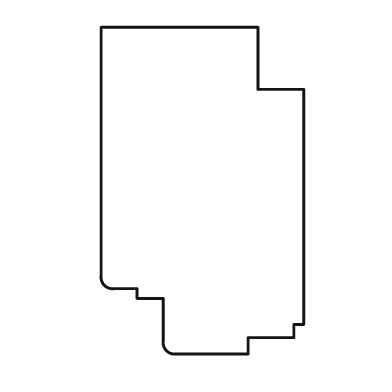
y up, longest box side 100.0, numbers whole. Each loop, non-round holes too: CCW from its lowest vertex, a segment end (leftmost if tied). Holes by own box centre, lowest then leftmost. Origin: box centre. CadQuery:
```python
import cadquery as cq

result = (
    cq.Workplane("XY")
    .moveTo(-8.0, -50.0)
    .lineTo(14.0, -50.0)
    .lineTo(14.0, -45.0)
    .lineTo(28.0, -45.0)
    .lineTo(28.0, -41.0)
    .lineTo(31.0, -41.0)
    .lineTo(31.0, 31.0)
    .lineTo(17.0, 31.0)
    .lineTo(17.0, 50.0)
    .lineTo(-31.0, 50.0)
    .lineTo(-31.0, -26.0)
    .threePointArc((-30.0, -29.0), (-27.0, -30.0))
    .lineTo(-20.0, -30.0)
    .lineTo(-20.0, -33.0)
    .lineTo(-12.0, -33.0)
    .lineTo(-12.0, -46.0)
    .threePointArc((-11.0, -49.0), (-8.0, -50.0))
    .close()
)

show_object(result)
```